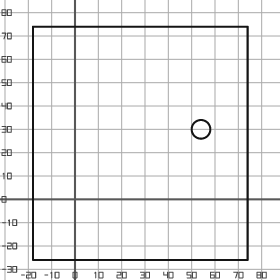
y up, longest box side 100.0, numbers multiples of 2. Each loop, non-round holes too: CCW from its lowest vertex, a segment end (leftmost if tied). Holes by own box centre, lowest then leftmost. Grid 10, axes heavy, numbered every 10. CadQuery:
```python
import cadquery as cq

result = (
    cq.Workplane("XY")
    .moveTo(-18.0, -26.0)
    .lineTo(74.0, -26.0)
    .lineTo(74.0, 74.0)
    .lineTo(-18.0, 74.0)
    .close()
    .moveTo(54.0, 30.0)
    .circle(4.0)
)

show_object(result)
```